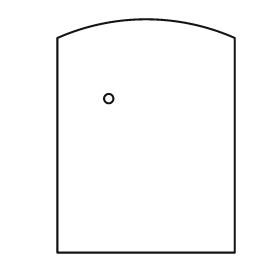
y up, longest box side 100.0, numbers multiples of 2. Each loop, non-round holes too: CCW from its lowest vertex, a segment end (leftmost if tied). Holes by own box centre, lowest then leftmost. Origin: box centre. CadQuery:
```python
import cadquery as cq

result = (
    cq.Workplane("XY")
    .moveTo(-38.0, -50.0)
    .lineTo(38.0, -50.0)
    .lineTo(38.0, 42.0)
    .threePointArc((0.0, 50.0), (-38.0, 42.0))
    .close()
    .moveTo(-16.0, 16.0)
    .circle(2.0)
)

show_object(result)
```